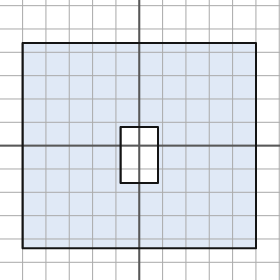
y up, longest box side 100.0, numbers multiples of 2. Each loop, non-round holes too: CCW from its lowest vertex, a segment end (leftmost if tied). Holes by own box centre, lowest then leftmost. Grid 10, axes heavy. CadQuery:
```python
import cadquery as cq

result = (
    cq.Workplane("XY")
    .moveTo(-50.0, -44.0)
    .lineTo(50.0, -44.0)
    .lineTo(50.0, 44.0)
    .lineTo(-50.0, 44.0)
    .close()
    .moveTo(-8.0, -16.0)
    .lineTo(8.0, -16.0)
    .lineTo(8.0, 8.0)
    .lineTo(-8.0, 8.0)
    .close()
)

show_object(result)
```